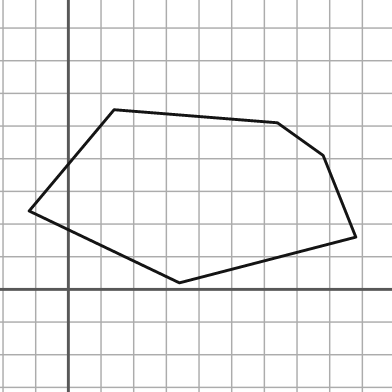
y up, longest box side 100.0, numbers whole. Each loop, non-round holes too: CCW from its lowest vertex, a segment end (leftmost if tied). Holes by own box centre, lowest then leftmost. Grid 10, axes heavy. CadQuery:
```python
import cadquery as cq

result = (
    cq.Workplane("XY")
    .moveTo(34.0, 2.0)
    .lineTo(88.0, 16.0)
    .lineTo(78.0, 41.0)
    .lineTo(64.0, 51.0)
    .lineTo(14.0, 55.0)
    .lineTo(-12.0, 24.0)
    .close()
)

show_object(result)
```